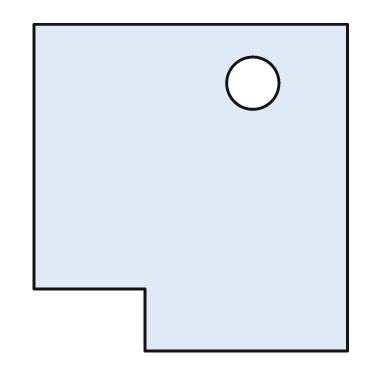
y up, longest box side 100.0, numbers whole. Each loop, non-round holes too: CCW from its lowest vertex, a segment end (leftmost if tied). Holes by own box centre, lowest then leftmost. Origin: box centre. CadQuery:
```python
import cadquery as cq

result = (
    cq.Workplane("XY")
    .moveTo(-14.0, -50.0)
    .lineTo(48.0, -50.0)
    .lineTo(48.0, 50.0)
    .lineTo(-48.0, 50.0)
    .lineTo(-48.0, -31.0)
    .lineTo(-14.0, -31.0)
    .close()
    .moveTo(19.0, 32.0)
    .circle(8.0)
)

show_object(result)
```